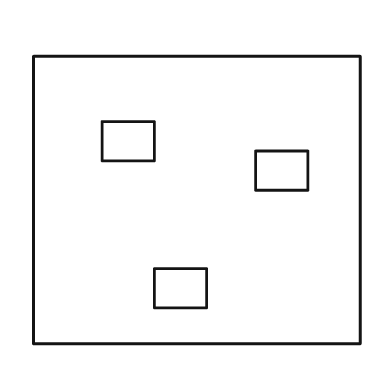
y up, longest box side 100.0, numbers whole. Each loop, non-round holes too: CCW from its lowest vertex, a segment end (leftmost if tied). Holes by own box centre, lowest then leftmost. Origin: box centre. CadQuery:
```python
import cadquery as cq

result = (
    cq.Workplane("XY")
    .moveTo(-50.0, -44.0)
    .lineTo(50.0, -44.0)
    .lineTo(50.0, 44.0)
    .lineTo(-50.0, 44.0)
    .close()
    .moveTo(-13.0, -33.0)
    .lineTo(3.0, -33.0)
    .lineTo(3.0, -21.0)
    .lineTo(-13.0, -21.0)
    .close()
    .moveTo(18.0, 3.0)
    .lineTo(34.0, 3.0)
    .lineTo(34.0, 15.0)
    .lineTo(18.0, 15.0)
    .close()
    .moveTo(-29.0, 12.0)
    .lineTo(-13.0, 12.0)
    .lineTo(-13.0, 24.0)
    .lineTo(-29.0, 24.0)
    .close()
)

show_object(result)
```